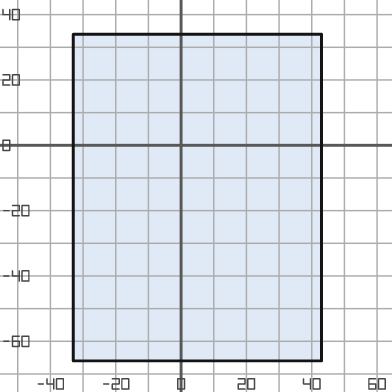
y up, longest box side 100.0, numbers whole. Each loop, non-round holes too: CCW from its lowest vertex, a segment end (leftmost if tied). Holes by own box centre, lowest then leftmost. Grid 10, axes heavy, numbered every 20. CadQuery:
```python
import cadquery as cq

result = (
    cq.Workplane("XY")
    .moveTo(-33.0, -66.0)
    .lineTo(43.0, -66.0)
    .lineTo(43.0, 34.0)
    .lineTo(-33.0, 34.0)
    .close()
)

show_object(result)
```